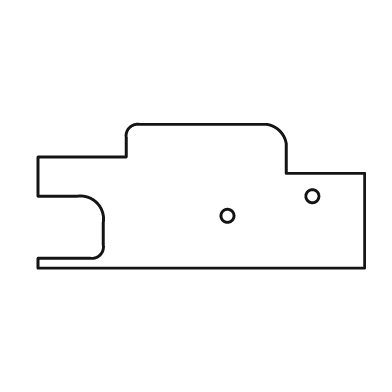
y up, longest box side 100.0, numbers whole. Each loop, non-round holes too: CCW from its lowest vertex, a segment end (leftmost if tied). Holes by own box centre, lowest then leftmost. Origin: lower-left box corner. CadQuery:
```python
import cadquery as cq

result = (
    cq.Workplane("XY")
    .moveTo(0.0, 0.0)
    .lineTo(100.0, 0.0)
    .lineTo(100.0, 29.0)
    .lineTo(76.0, 29.0)
    .lineTo(76.0, 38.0)
    .threePointArc((74.0, 42.0), (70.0, 44.0))
    .lineTo(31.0, 44.0)
    .threePointArc((28.0, 43.0), (27.0, 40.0))
    .lineTo(27.0, 34.0)
    .lineTo(0.0, 34.0)
    .lineTo(0.0, 22.0)
    .lineTo(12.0, 22.0)
    .threePointArc((18.0, 20.0), (20.0, 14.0))
    .lineTo(20.0, 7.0)
    .threePointArc((19.0, 4.0), (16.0, 3.0))
    .lineTo(0.0, 3.0)
    .close()
    .moveTo(58.0, 16.0)
    .circle(2.0)
    .moveTo(84.0, 22.0)
    .circle(2.0)
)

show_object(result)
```